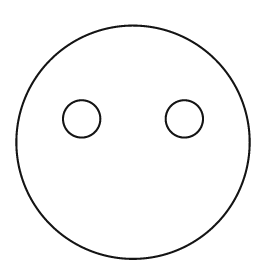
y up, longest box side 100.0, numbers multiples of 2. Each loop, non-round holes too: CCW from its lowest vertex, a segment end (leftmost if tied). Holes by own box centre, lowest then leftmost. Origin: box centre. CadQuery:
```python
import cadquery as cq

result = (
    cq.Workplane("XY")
    .moveTo(0.0, 0.0)
    .circle(50.0)
    .moveTo(-22.0, 10.0)
    .circle(8.0)
    .moveTo(22.0, 10.0)
    .circle(8.0)
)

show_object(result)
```